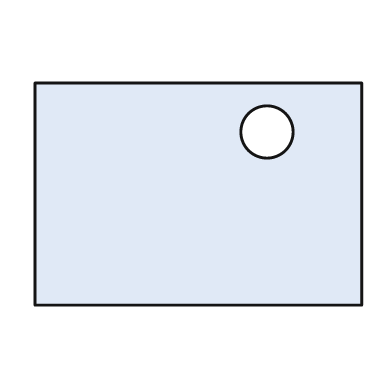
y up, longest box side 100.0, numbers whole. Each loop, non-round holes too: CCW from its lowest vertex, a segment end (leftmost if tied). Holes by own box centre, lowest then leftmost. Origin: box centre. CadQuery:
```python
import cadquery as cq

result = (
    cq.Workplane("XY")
    .moveTo(-50.0, -34.0)
    .lineTo(50.0, -34.0)
    .lineTo(50.0, 34.0)
    .lineTo(-50.0, 34.0)
    .close()
    .moveTo(21.0, 19.0)
    .circle(8.0)
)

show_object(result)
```